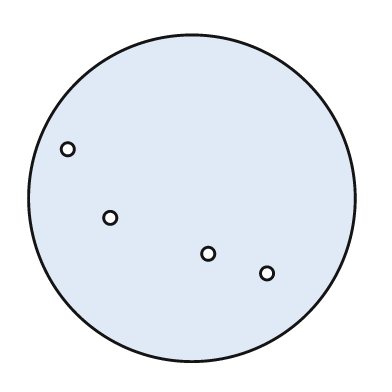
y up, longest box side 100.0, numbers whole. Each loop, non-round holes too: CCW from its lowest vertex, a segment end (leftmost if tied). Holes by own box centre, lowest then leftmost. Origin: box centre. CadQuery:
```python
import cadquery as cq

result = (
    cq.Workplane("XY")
    .moveTo(0.0, 0.0)
    .circle(50.0)
    .moveTo(23.0, -23.0)
    .circle(2.0)
    .moveTo(5.0, -17.0)
    .circle(2.0)
    .moveTo(-25.0, -6.0)
    .circle(2.0)
    .moveTo(-38.0, 15.0)
    .circle(2.0)
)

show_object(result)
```